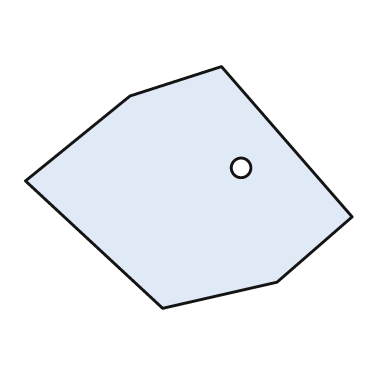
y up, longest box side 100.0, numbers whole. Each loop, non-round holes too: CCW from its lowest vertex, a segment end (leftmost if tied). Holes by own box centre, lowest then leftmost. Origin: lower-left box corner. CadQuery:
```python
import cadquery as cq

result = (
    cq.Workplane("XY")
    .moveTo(42.0, 0.0)
    .lineTo(77.0, 8.0)
    .lineTo(100.0, 28.0)
    .lineTo(60.0, 74.0)
    .lineTo(32.0, 65.0)
    .lineTo(0.0, 39.0)
    .close()
    .moveTo(66.0, 43.0)
    .circle(3.0)
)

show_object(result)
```